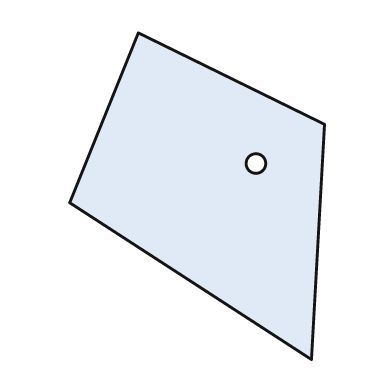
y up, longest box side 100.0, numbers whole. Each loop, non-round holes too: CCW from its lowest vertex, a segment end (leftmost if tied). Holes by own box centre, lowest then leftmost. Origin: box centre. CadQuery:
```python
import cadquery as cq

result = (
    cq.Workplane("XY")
    .moveTo(35.0, -50.0)
    .lineTo(39.0, 22.0)
    .lineTo(-18.0, 50.0)
    .lineTo(-39.0, -2.0)
    .close()
    .moveTo(18.0, 10.0)
    .circle(3.0)
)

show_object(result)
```